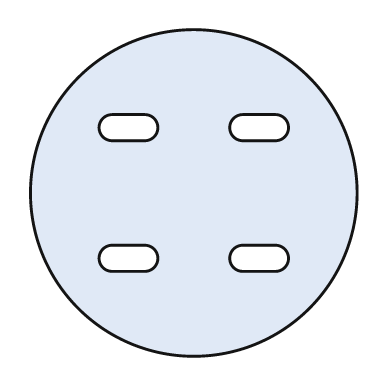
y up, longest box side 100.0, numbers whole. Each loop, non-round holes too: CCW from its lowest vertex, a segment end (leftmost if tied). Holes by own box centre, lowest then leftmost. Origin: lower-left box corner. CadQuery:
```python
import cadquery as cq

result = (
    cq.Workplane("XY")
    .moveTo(50.0, 50.0)
    .circle(50.0)
    .moveTo(25.0, 26.0)
    .lineTo(35.0, 26.0)
    .threePointArc((39.0, 30.0), (35.0, 34.0))
    .lineTo(25.0, 34.0)
    .threePointArc((21.0, 30.0), (25.0, 26.0))
    .close()
    .moveTo(65.0, 26.0)
    .lineTo(75.0, 26.0)
    .threePointArc((79.0, 30.0), (75.0, 34.0))
    .lineTo(65.0, 34.0)
    .threePointArc((61.0, 30.0), (65.0, 26.0))
    .close()
    .moveTo(25.0, 66.0)
    .lineTo(35.0, 66.0)
    .threePointArc((39.0, 70.0), (35.0, 74.0))
    .lineTo(25.0, 74.0)
    .threePointArc((21.0, 70.0), (25.0, 66.0))
    .close()
    .moveTo(65.0, 66.0)
    .lineTo(75.0, 66.0)
    .threePointArc((79.0, 70.0), (75.0, 74.0))
    .lineTo(65.0, 74.0)
    .threePointArc((61.0, 70.0), (65.0, 66.0))
    .close()
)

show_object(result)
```